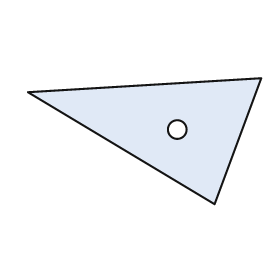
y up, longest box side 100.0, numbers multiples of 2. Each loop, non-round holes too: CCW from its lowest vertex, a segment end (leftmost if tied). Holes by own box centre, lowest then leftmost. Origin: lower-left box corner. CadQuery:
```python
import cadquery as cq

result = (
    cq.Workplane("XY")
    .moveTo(80.0, 0.0)
    .lineTo(100.0, 54.0)
    .lineTo(0.0, 48.0)
    .close()
    .moveTo(64.0, 32.0)
    .circle(4.0)
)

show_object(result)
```